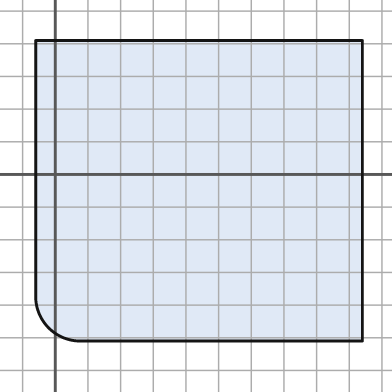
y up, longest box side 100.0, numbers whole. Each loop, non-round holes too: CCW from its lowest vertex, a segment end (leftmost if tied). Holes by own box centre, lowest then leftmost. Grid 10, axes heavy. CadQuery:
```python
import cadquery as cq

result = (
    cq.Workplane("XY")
    .moveTo(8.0, -51.0)
    .lineTo(94.0, -51.0)
    .lineTo(94.0, 41.0)
    .lineTo(-6.0, 41.0)
    .lineTo(-6.0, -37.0)
    .threePointArc((-2.0, -47.0), (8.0, -51.0))
    .close()
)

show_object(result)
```